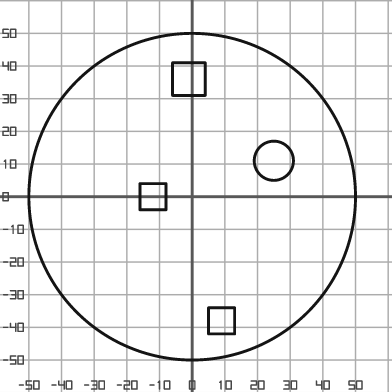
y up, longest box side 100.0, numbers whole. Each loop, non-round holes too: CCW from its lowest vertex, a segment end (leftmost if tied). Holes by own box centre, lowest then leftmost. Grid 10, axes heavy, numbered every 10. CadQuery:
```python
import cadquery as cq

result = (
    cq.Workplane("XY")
    .moveTo(0.0, 0.0)
    .circle(50.0)
    .moveTo(5.0, -42.0)
    .lineTo(13.0, -42.0)
    .lineTo(13.0, -34.0)
    .lineTo(5.0, -34.0)
    .close()
    .moveTo(-16.0, -4.0)
    .lineTo(-8.0, -4.0)
    .lineTo(-8.0, 4.0)
    .lineTo(-16.0, 4.0)
    .close()
    .moveTo(25.0, 11.0)
    .circle(6.0)
    .moveTo(-6.0, 31.0)
    .lineTo(4.0, 31.0)
    .lineTo(4.0, 41.0)
    .lineTo(-6.0, 41.0)
    .close()
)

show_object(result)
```